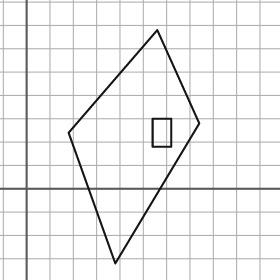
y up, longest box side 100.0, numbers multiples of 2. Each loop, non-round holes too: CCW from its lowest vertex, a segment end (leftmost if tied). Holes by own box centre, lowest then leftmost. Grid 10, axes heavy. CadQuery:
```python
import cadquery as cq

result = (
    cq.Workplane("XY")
    .moveTo(38.0, -32.0)
    .lineTo(74.0, 28.0)
    .lineTo(56.0, 68.0)
    .lineTo(18.0, 24.0)
    .close()
    .moveTo(54.0, 18.0)
    .lineTo(62.0, 18.0)
    .lineTo(62.0, 30.0)
    .lineTo(54.0, 30.0)
    .close()
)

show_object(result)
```